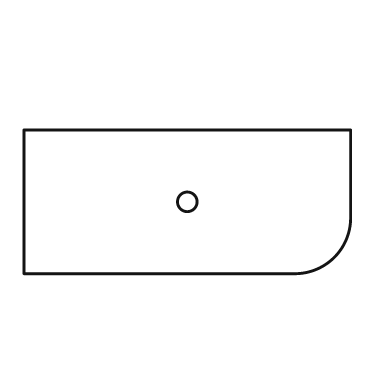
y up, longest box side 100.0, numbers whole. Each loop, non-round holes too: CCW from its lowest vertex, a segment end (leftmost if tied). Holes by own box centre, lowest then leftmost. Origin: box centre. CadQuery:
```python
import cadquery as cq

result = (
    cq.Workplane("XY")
    .moveTo(-50.0, -22.0)
    .lineTo(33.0, -22.0)
    .threePointArc((45.0, -17.0), (50.0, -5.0))
    .lineTo(50.0, 22.0)
    .lineTo(-50.0, 22.0)
    .close()
    .moveTo(0.0, 0.0)
    .circle(3.0)
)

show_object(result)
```